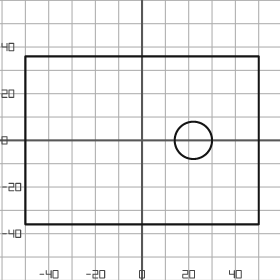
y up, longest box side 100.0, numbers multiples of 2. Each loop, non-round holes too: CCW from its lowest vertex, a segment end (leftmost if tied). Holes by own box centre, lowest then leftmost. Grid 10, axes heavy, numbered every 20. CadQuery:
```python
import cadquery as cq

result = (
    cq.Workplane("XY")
    .moveTo(-50.0, -36.0)
    .lineTo(50.0, -36.0)
    .lineTo(50.0, 36.0)
    .lineTo(-50.0, 36.0)
    .close()
    .moveTo(22.0, 0.0)
    .circle(8.0)
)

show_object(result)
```